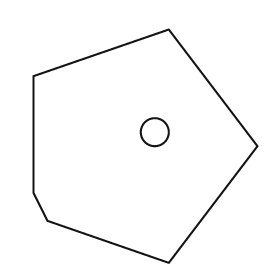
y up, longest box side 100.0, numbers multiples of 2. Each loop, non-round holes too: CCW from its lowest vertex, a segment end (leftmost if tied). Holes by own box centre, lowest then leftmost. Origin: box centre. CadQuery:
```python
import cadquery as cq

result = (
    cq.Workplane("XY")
    .moveTo(10.0, -50.0)
    .lineTo(48.0, 0.0)
    .lineTo(10.0, 50.0)
    .lineTo(-48.0, 30.0)
    .lineTo(-48.0, -20.0)
    .lineTo(-42.0, -32.0)
    .close()
    .moveTo(4.0, 6.0)
    .circle(6.0)
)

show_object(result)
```